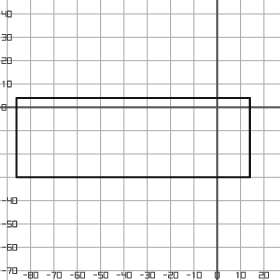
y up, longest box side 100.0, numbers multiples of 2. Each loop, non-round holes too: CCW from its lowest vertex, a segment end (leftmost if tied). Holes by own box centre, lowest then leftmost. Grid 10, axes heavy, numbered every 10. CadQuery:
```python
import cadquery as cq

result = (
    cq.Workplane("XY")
    .moveTo(-86.0, -30.0)
    .lineTo(14.0, -30.0)
    .lineTo(14.0, 4.0)
    .lineTo(-86.0, 4.0)
    .close()
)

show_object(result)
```